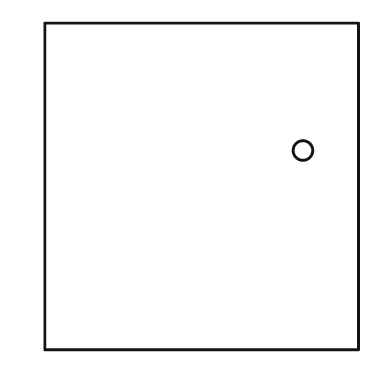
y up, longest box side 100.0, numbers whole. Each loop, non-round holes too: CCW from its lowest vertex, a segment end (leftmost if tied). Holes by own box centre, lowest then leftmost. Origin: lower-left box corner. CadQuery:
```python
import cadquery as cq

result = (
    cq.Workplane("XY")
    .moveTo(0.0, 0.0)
    .lineTo(96.0, 0.0)
    .lineTo(96.0, 100.0)
    .lineTo(0.0, 100.0)
    .close()
    .moveTo(79.0, 61.0)
    .circle(3.0)
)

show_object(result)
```